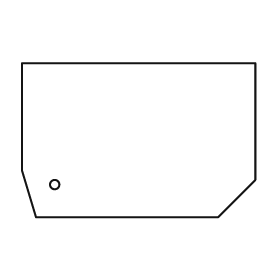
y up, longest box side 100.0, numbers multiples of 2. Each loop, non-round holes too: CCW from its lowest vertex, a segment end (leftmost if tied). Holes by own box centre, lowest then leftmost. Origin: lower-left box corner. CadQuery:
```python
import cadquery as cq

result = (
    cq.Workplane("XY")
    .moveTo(6.0, 0.0)
    .lineTo(84.0, 0.0)
    .lineTo(100.0, 16.0)
    .lineTo(100.0, 66.0)
    .lineTo(0.0, 66.0)
    .lineTo(0.0, 20.0)
    .close()
    .moveTo(14.0, 14.0)
    .circle(2.0)
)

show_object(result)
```